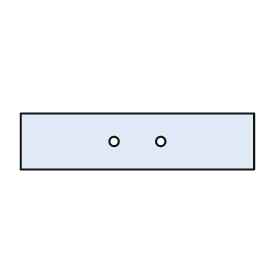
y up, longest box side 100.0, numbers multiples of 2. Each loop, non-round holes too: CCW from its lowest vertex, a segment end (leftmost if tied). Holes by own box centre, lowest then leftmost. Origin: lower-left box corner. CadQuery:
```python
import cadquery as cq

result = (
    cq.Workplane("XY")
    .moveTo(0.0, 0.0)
    .lineTo(100.0, 0.0)
    .lineTo(100.0, 24.0)
    .lineTo(0.0, 24.0)
    .close()
    .moveTo(40.0, 12.0)
    .circle(2.0)
    .moveTo(60.0, 12.0)
    .circle(2.0)
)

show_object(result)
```